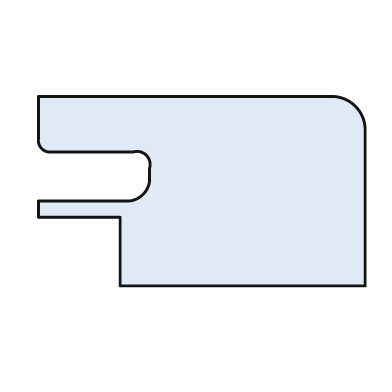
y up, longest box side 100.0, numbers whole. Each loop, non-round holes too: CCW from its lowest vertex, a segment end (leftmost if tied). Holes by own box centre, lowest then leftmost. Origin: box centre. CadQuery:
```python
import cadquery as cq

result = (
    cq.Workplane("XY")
    .moveTo(-25.0, -29.0)
    .lineTo(50.0, -29.0)
    .lineTo(50.0, 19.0)
    .threePointArc((47.0, 26.0), (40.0, 29.0))
    .lineTo(-50.0, 29.0)
    .lineTo(-50.0, 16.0)
    .threePointArc((-49.0, 13.0), (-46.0, 12.0))
    .lineTo(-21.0, 12.0)
    .threePointArc((-17.0, 11.0), (-16.0, 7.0))
    .lineTo(-16.0, 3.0)
    .threePointArc((-18.0, -1.0), (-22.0, -3.0))
    .lineTo(-50.0, -3.0)
    .lineTo(-50.0, -8.0)
    .lineTo(-25.0, -8.0)
    .close()
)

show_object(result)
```